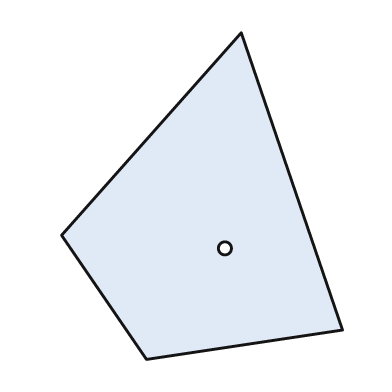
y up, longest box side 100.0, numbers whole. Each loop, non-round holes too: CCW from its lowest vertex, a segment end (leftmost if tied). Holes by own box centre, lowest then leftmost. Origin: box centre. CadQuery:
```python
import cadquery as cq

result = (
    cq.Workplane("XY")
    .moveTo(-17.0, -50.0)
    .lineTo(43.0, -41.0)
    .lineTo(12.0, 50.0)
    .lineTo(-43.0, -12.0)
    .close()
    .moveTo(7.0, -16.0)
    .circle(2.0)
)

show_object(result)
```